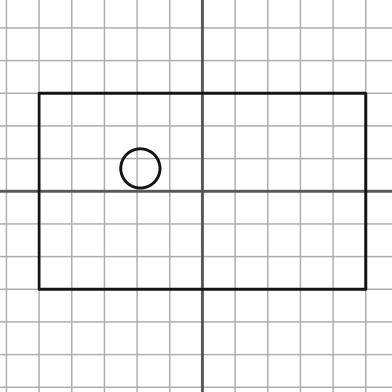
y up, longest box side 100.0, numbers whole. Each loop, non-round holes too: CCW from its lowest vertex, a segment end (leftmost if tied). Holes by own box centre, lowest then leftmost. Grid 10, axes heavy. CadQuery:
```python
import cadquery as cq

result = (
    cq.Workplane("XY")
    .moveTo(-50.0, -30.0)
    .lineTo(50.0, -30.0)
    .lineTo(50.0, 30.0)
    .lineTo(-50.0, 30.0)
    .close()
    .moveTo(-19.0, 7.0)
    .circle(6.0)
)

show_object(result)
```